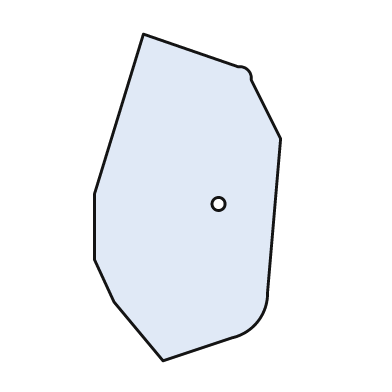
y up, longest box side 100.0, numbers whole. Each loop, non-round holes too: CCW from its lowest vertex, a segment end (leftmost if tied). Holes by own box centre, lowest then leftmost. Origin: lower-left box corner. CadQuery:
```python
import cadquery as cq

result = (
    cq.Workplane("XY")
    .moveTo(21.0, 0.0)
    .lineTo(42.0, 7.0)
    .threePointArc((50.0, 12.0), (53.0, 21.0))
    .lineTo(57.0, 68.0)
    .lineTo(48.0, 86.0)
    .threePointArc((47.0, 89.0), (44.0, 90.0))
    .lineTo(15.0, 100.0)
    .lineTo(0.0, 51.0)
    .lineTo(0.0, 31.0)
    .lineTo(6.0, 18.0)
    .close()
    .moveTo(38.0, 48.0)
    .circle(2.0)
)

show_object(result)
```